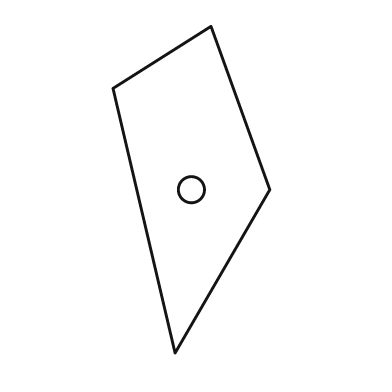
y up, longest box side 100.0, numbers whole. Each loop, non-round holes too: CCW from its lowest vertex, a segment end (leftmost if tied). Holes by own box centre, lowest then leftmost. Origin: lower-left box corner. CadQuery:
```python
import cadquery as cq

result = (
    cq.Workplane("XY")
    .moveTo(19.0, 0.0)
    .lineTo(48.0, 50.0)
    .lineTo(30.0, 100.0)
    .lineTo(0.0, 81.0)
    .close()
    .moveTo(24.0, 50.0)
    .circle(4.0)
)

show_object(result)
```